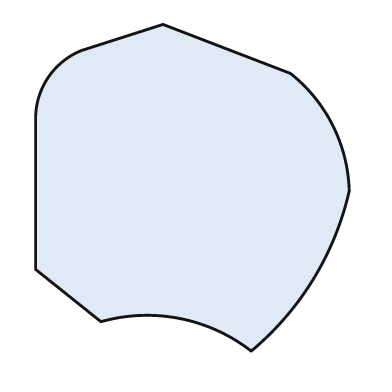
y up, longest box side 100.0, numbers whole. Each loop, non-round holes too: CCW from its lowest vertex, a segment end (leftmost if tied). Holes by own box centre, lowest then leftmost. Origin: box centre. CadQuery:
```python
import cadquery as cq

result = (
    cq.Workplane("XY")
    .moveTo(18.0, -50.0)
    .threePointArc((37.0, -28.0), (48.0, -1.0))
    .threePointArc((43.0, 19.0), (30.0, 35.0))
    .lineTo(-9.0, 50.0)
    .lineTo(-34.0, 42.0)
    .threePointArc((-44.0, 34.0), (-48.0, 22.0))
    .lineTo(-48.0, -25.0)
    .lineTo(-28.0, -41.0)
    .threePointArc((-4.0, -40.0), (18.0, -50.0))
    .close()
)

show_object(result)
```